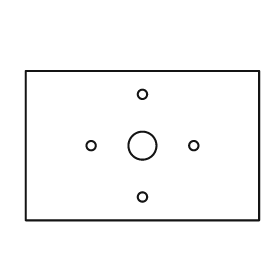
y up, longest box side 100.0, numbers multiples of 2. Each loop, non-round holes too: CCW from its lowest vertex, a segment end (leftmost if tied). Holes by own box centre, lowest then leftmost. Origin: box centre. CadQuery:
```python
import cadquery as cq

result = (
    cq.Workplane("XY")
    .moveTo(-50.0, -32.0)
    .lineTo(50.0, -32.0)
    .lineTo(50.0, 32.0)
    .lineTo(-50.0, 32.0)
    .close()
    .moveTo(0.0, -22.0)
    .circle(2.0)
    .moveTo(-22.0, 0.0)
    .circle(2.0)
    .moveTo(0.0, 0.0)
    .circle(6.0)
    .moveTo(22.0, 0.0)
    .circle(2.0)
    .moveTo(0.0, 22.0)
    .circle(2.0)
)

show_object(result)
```